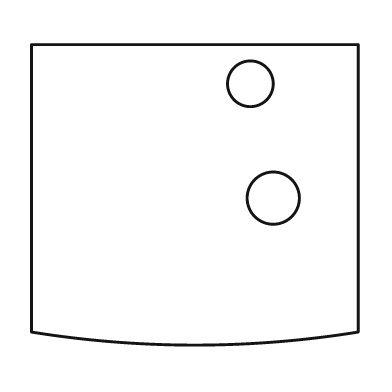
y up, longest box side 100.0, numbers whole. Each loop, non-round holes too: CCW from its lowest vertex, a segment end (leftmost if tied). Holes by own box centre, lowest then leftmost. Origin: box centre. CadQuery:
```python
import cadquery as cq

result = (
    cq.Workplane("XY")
    .moveTo(-50.0, -42.0)
    .threePointArc((0.0, -46.0), (50.0, -42.0))
    .lineTo(50.0, 46.0)
    .lineTo(-50.0, 46.0)
    .close()
    .moveTo(24.0, -1.0)
    .circle(8.0)
    .moveTo(17.0, 34.0)
    .circle(7.0)
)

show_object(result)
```